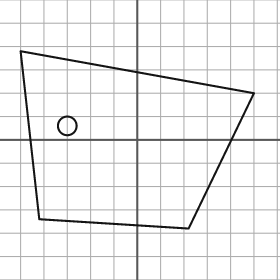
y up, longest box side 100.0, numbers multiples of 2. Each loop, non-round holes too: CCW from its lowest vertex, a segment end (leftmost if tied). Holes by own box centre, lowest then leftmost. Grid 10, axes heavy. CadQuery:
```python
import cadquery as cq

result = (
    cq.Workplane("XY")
    .moveTo(22.0, -38.0)
    .lineTo(50.0, 20.0)
    .lineTo(-50.0, 38.0)
    .lineTo(-42.0, -34.0)
    .close()
    .moveTo(-30.0, 6.0)
    .circle(4.0)
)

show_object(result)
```